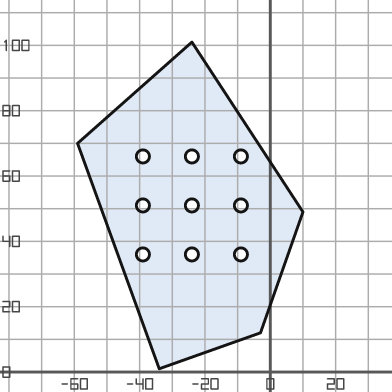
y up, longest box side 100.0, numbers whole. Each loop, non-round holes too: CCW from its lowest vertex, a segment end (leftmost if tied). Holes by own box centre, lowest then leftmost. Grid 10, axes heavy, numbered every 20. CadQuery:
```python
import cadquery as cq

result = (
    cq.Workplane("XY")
    .moveTo(-34.0, 1.0)
    .lineTo(-3.0, 12.0)
    .lineTo(10.0, 49.0)
    .lineTo(-24.0, 101.0)
    .lineTo(-59.0, 70.0)
    .close()
    .moveTo(-39.0, 36.0)
    .circle(2.0)
    .moveTo(-24.0, 36.0)
    .circle(2.0)
    .moveTo(-9.0, 36.0)
    .circle(2.0)
    .moveTo(-39.0, 51.0)
    .circle(2.0)
    .moveTo(-24.0, 51.0)
    .circle(2.0)
    .moveTo(-9.0, 51.0)
    .circle(2.0)
    .moveTo(-39.0, 66.0)
    .circle(2.0)
    .moveTo(-24.0, 66.0)
    .circle(2.0)
    .moveTo(-9.0, 66.0)
    .circle(2.0)
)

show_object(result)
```